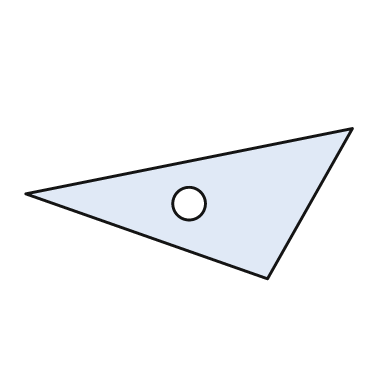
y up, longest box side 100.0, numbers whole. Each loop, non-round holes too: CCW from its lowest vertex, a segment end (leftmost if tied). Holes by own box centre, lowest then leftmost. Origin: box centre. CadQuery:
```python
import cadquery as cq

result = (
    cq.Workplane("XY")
    .moveTo(24.0, -23.0)
    .lineTo(50.0, 23.0)
    .lineTo(-50.0, 3.0)
    .close()
    .moveTo(0.0, 0.0)
    .circle(5.0)
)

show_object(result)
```